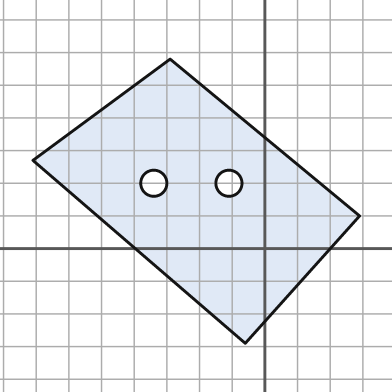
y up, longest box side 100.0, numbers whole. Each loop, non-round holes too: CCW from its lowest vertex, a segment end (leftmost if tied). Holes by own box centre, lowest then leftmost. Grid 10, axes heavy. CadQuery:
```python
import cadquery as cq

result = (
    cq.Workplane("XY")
    .moveTo(-6.0, -29.0)
    .lineTo(29.0, 10.0)
    .lineTo(-29.0, 58.0)
    .lineTo(-71.0, 27.0)
    .close()
    .moveTo(-34.0, 20.0)
    .circle(4.0)
    .moveTo(-11.0, 20.0)
    .circle(4.0)
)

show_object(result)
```